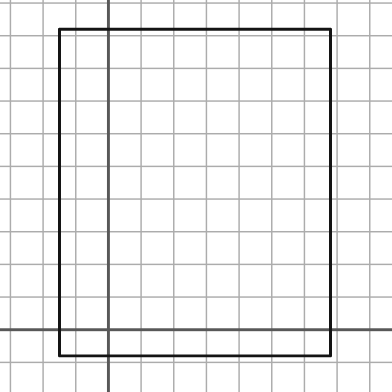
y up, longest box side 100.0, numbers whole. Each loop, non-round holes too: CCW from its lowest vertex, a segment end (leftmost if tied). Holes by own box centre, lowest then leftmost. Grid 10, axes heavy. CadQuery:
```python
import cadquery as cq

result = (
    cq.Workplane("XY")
    .moveTo(-15.0, -8.0)
    .lineTo(68.0, -8.0)
    .lineTo(68.0, 92.0)
    .lineTo(-15.0, 92.0)
    .close()
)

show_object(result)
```